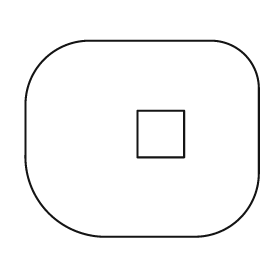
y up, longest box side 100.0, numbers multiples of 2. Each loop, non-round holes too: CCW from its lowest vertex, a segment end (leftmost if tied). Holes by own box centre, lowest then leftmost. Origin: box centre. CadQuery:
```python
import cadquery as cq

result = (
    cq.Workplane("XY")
    .moveTo(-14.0, -42.0)
    .lineTo(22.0, -42.0)
    .threePointArc((42.0, -34.0), (50.0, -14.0))
    .lineTo(50.0, 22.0)
    .threePointArc((44.0, 36.0), (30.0, 42.0))
    .lineTo(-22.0, 42.0)
    .threePointArc((-42.0, 34.0), (-50.0, 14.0))
    .lineTo(-50.0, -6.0)
    .threePointArc((-40.0, -32.0), (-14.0, -42.0))
    .close()
    .moveTo(-2.0, -8.0)
    .lineTo(18.0, -8.0)
    .lineTo(18.0, 12.0)
    .lineTo(-2.0, 12.0)
    .close()
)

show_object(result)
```